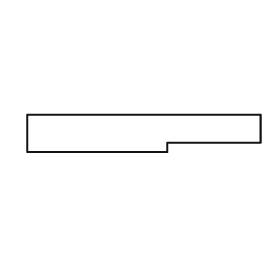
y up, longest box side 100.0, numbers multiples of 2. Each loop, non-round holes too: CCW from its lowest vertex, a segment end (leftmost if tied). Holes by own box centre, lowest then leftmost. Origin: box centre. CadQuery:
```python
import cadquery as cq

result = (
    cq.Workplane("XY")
    .moveTo(-50.0, -8.0)
    .lineTo(10.0, -8.0)
    .lineTo(10.0, -4.0)
    .lineTo(50.0, -4.0)
    .lineTo(50.0, 8.0)
    .lineTo(-50.0, 8.0)
    .close()
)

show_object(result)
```